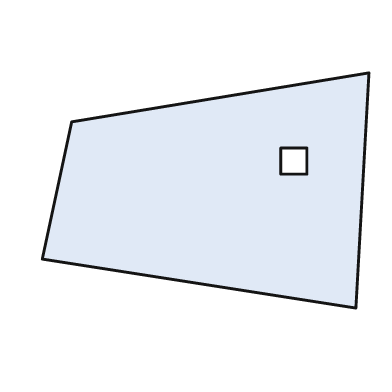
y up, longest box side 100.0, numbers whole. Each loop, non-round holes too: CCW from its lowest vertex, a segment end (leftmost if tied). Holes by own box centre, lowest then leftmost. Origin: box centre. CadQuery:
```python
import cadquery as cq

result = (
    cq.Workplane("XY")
    .moveTo(46.0, -36.0)
    .lineTo(50.0, 36.0)
    .lineTo(-41.0, 21.0)
    .lineTo(-50.0, -21.0)
    .close()
    .moveTo(23.0, 5.0)
    .lineTo(31.0, 5.0)
    .lineTo(31.0, 13.0)
    .lineTo(23.0, 13.0)
    .close()
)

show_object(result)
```